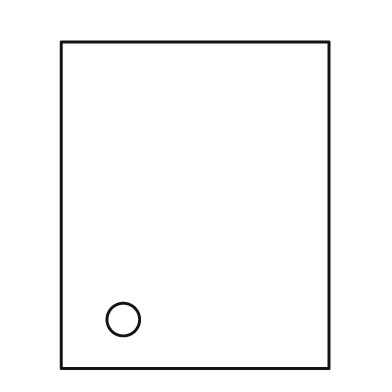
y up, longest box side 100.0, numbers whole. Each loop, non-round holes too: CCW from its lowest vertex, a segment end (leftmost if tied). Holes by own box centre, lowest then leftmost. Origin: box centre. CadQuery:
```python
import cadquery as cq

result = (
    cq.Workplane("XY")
    .moveTo(-41.0, -50.0)
    .lineTo(41.0, -50.0)
    .lineTo(41.0, 50.0)
    .lineTo(-41.0, 50.0)
    .close()
    .moveTo(-22.0, -35.0)
    .circle(5.0)
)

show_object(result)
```